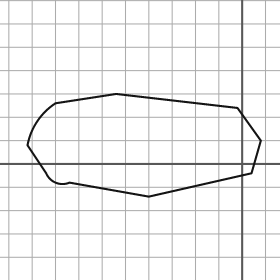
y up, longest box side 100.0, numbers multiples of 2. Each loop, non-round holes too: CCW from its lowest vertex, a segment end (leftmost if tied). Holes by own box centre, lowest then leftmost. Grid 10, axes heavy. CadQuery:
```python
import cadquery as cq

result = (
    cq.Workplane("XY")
    .moveTo(-40.0, -14.0)
    .lineTo(4.0, -4.0)
    .lineTo(8.0, 10.0)
    .lineTo(-2.0, 24.0)
    .lineTo(-54.0, 30.0)
    .lineTo(-80.0, 26.0)
    .threePointArc((-88.0, 18.0), (-92.0, 8.0))
    .lineTo(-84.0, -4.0)
    .threePointArc((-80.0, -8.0), (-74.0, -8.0))
    .close()
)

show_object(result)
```